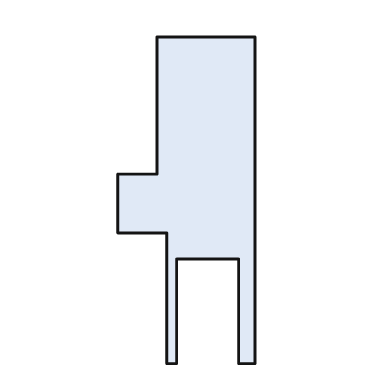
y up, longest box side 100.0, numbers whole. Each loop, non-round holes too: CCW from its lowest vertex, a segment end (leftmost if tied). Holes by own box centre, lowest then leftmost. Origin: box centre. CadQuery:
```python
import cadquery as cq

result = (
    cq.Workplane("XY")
    .moveTo(-6.0, -50.0)
    .lineTo(-3.0, -50.0)
    .lineTo(-3.0, -18.0)
    .lineTo(16.0, -18.0)
    .lineTo(16.0, -50.0)
    .lineTo(21.0, -50.0)
    .lineTo(21.0, 50.0)
    .lineTo(-9.0, 50.0)
    .lineTo(-9.0, 8.0)
    .lineTo(-21.0, 8.0)
    .lineTo(-21.0, -10.0)
    .lineTo(-6.0, -10.0)
    .close()
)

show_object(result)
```